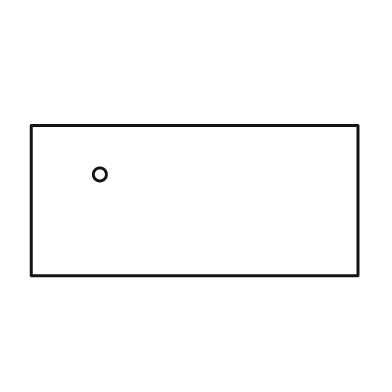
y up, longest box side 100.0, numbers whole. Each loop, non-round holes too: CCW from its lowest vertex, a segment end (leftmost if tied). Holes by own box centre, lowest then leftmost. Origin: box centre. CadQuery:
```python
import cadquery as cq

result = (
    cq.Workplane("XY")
    .moveTo(-50.0, -23.0)
    .lineTo(50.0, -23.0)
    .lineTo(50.0, 23.0)
    .lineTo(-50.0, 23.0)
    .close()
    .moveTo(-29.0, 8.0)
    .circle(2.0)
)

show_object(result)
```